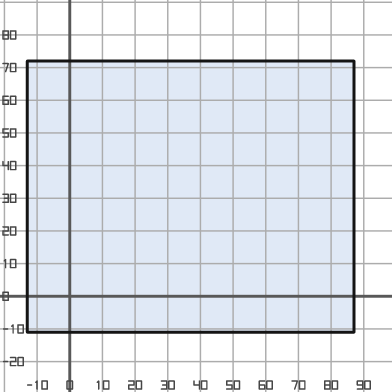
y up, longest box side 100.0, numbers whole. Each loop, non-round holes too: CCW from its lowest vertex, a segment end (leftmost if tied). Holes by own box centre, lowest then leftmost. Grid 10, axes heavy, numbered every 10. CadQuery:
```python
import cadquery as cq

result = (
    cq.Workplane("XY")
    .moveTo(-13.0, -11.0)
    .lineTo(87.0, -11.0)
    .lineTo(87.0, 72.0)
    .lineTo(-13.0, 72.0)
    .close()
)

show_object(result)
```